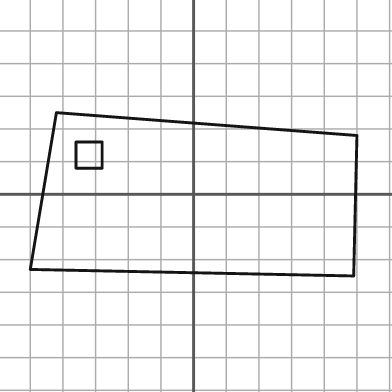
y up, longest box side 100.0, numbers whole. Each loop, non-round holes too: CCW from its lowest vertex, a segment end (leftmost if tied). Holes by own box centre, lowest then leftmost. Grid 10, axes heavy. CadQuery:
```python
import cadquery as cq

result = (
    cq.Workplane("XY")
    .moveTo(49.0, -25.0)
    .lineTo(50.0, 18.0)
    .lineTo(-42.0, 25.0)
    .lineTo(-50.0, -23.0)
    .close()
    .moveTo(-36.0, 8.0)
    .lineTo(-28.0, 8.0)
    .lineTo(-28.0, 16.0)
    .lineTo(-36.0, 16.0)
    .close()
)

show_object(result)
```